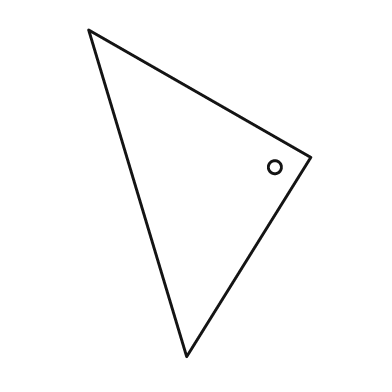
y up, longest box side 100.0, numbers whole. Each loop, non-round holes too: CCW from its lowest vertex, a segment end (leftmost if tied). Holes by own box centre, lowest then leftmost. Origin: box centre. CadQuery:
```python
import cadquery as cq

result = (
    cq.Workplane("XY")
    .moveTo(-4.0, -50.0)
    .lineTo(34.0, 11.0)
    .lineTo(-34.0, 50.0)
    .close()
    .moveTo(23.0, 8.0)
    .circle(2.0)
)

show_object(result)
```